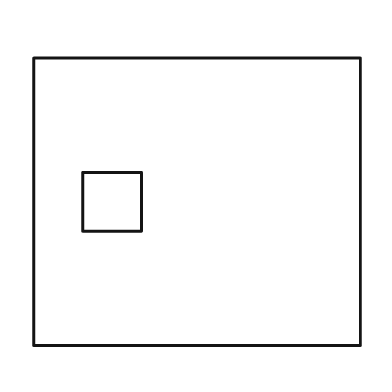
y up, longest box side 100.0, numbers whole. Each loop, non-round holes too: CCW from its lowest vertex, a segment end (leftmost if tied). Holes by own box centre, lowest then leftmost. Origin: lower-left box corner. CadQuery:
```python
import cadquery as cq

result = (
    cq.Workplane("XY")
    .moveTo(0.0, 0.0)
    .lineTo(100.0, 0.0)
    .lineTo(100.0, 88.0)
    .lineTo(0.0, 88.0)
    .close()
    .moveTo(15.0, 35.0)
    .lineTo(33.0, 35.0)
    .lineTo(33.0, 53.0)
    .lineTo(15.0, 53.0)
    .close()
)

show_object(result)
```